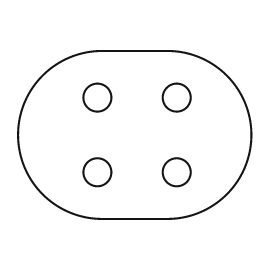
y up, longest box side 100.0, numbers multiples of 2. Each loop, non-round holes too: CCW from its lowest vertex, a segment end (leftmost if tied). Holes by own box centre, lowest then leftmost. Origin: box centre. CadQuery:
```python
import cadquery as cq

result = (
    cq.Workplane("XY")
    .moveTo(-14.0, -36.0)
    .lineTo(14.0, -36.0)
    .threePointArc((50.0, 0.0), (14.0, 36.0))
    .lineTo(-14.0, 36.0)
    .threePointArc((-50.0, 0.0), (-14.0, -36.0))
    .close()
    .moveTo(-16.0, -16.0)
    .circle(6.0)
    .moveTo(18.0, -16.0)
    .circle(6.0)
    .moveTo(-16.0, 16.0)
    .circle(6.0)
    .moveTo(18.0, 16.0)
    .circle(6.0)
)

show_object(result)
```